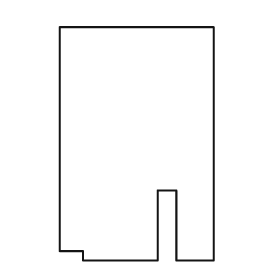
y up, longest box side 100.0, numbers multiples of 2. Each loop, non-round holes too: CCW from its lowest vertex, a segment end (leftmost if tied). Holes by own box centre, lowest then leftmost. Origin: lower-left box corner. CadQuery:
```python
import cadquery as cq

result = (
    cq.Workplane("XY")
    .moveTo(10.0, 0.0)
    .lineTo(42.0, 0.0)
    .lineTo(42.0, 30.0)
    .lineTo(50.0, 30.0)
    .lineTo(50.0, 0.0)
    .lineTo(66.0, 0.0)
    .lineTo(66.0, 100.0)
    .lineTo(0.0, 100.0)
    .lineTo(0.0, 4.0)
    .lineTo(10.0, 4.0)
    .close()
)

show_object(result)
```